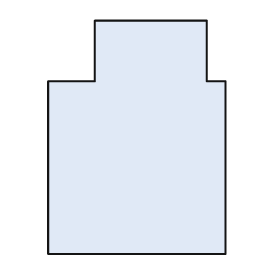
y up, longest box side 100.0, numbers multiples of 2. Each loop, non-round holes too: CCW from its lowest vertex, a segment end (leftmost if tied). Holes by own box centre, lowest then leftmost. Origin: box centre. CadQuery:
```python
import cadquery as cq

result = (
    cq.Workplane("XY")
    .moveTo(-38.0, -50.0)
    .lineTo(38.0, -50.0)
    .lineTo(38.0, 24.0)
    .lineTo(30.0, 24.0)
    .lineTo(30.0, 50.0)
    .lineTo(-18.0, 50.0)
    .lineTo(-18.0, 24.0)
    .lineTo(-38.0, 24.0)
    .close()
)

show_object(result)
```